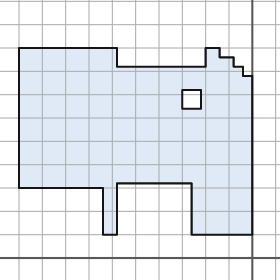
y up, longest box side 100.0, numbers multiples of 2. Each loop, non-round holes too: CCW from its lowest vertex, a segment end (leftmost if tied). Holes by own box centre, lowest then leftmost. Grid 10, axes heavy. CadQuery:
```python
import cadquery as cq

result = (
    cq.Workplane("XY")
    .moveTo(-64.0, 10.0)
    .lineTo(-58.0, 10.0)
    .lineTo(-58.0, 32.0)
    .lineTo(-26.0, 32.0)
    .lineTo(-26.0, 10.0)
    .lineTo(0.0, 10.0)
    .lineTo(0.0, 78.0)
    .lineTo(-4.0, 78.0)
    .lineTo(-4.0, 82.0)
    .lineTo(-8.0, 82.0)
    .lineTo(-8.0, 86.0)
    .lineTo(-14.0, 86.0)
    .lineTo(-14.0, 90.0)
    .lineTo(-20.0, 90.0)
    .lineTo(-20.0, 82.0)
    .lineTo(-58.0, 82.0)
    .lineTo(-58.0, 90.0)
    .lineTo(-100.0, 90.0)
    .lineTo(-100.0, 30.0)
    .lineTo(-64.0, 30.0)
    .close()
    .moveTo(-30.0, 64.0)
    .lineTo(-22.0, 64.0)
    .lineTo(-22.0, 72.0)
    .lineTo(-30.0, 72.0)
    .close()
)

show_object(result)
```